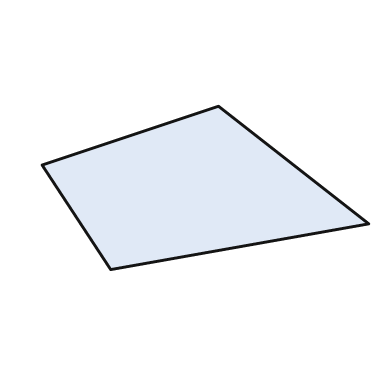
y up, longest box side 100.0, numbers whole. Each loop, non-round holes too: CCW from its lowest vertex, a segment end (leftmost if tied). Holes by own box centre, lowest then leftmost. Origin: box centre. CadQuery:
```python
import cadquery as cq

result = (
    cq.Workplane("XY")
    .moveTo(-29.0, -25.0)
    .lineTo(50.0, -11.0)
    .lineTo(4.0, 25.0)
    .lineTo(-50.0, 7.0)
    .close()
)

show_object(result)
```